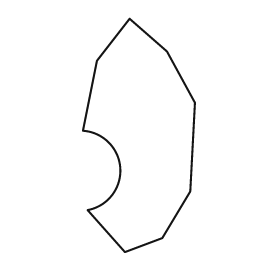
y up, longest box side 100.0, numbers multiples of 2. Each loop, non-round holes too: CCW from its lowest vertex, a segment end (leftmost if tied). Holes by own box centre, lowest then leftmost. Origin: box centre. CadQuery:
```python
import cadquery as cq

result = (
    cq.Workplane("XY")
    .moveTo(-6.0, -50.0)
    .lineTo(10.0, -44.0)
    .lineTo(22.0, -24.0)
    .lineTo(24.0, 14.0)
    .lineTo(12.0, 36.0)
    .lineTo(-4.0, 50.0)
    .lineTo(-18.0, 32.0)
    .lineTo(-24.0, 2.0)
    .threePointArc((-8.0, -14.0), (-22.0, -32.0))
    .close()
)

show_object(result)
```